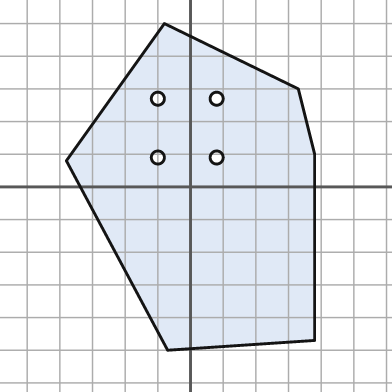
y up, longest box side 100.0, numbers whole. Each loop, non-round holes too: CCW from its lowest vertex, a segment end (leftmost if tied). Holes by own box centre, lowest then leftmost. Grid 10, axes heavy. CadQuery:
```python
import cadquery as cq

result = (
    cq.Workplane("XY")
    .moveTo(-7.0, -50.0)
    .lineTo(38.0, -47.0)
    .lineTo(38.0, 10.0)
    .lineTo(33.0, 30.0)
    .lineTo(-8.0, 50.0)
    .lineTo(-38.0, 8.0)
    .close()
    .moveTo(-10.0, 9.0)
    .circle(2.0)
    .moveTo(8.0, 9.0)
    .circle(2.0)
    .moveTo(-10.0, 27.0)
    .circle(2.0)
    .moveTo(8.0, 27.0)
    .circle(2.0)
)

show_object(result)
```